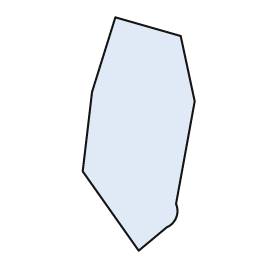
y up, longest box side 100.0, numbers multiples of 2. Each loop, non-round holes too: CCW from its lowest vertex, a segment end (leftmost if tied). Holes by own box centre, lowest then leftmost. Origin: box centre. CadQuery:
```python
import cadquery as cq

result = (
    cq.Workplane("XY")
    .moveTo(0.0, -50.0)
    .lineTo(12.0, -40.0)
    .threePointArc((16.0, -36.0), (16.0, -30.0))
    .lineTo(24.0, 14.0)
    .lineTo(18.0, 42.0)
    .lineTo(-10.0, 50.0)
    .lineTo(-20.0, 18.0)
    .lineTo(-24.0, -16.0)
    .close()
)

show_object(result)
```